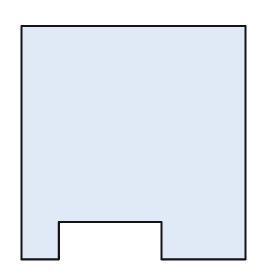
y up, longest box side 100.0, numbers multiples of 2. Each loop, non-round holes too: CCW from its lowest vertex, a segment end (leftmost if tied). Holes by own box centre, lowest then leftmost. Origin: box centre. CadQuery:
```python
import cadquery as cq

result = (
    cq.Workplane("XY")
    .moveTo(-48.0, -50.0)
    .lineTo(-32.0, -50.0)
    .lineTo(-32.0, -34.0)
    .lineTo(12.0, -34.0)
    .lineTo(12.0, -50.0)
    .lineTo(48.0, -50.0)
    .lineTo(48.0, 50.0)
    .lineTo(-48.0, 50.0)
    .close()
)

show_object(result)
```